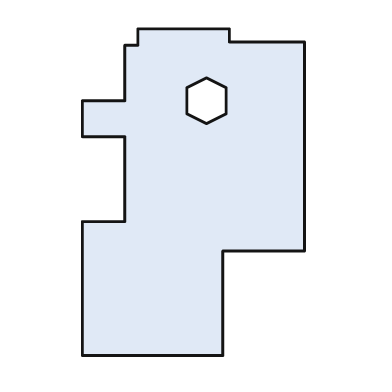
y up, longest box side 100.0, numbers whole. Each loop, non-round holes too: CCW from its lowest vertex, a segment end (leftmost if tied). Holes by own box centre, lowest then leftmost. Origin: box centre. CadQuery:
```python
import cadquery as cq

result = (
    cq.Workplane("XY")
    .moveTo(-34.0, -50.0)
    .lineTo(9.0, -50.0)
    .lineTo(9.0, -18.0)
    .lineTo(34.0, -18.0)
    .lineTo(34.0, 46.0)
    .lineTo(11.0, 46.0)
    .lineTo(11.0, 50.0)
    .lineTo(-17.0, 50.0)
    .lineTo(-17.0, 45.0)
    .lineTo(-21.0, 45.0)
    .lineTo(-21.0, 28.0)
    .lineTo(-34.0, 28.0)
    .lineTo(-34.0, 17.0)
    .lineTo(-21.0, 17.0)
    .lineTo(-21.0, -9.0)
    .lineTo(-34.0, -9.0)
    .close()
    .moveTo(4.0, 21.0)
    .lineTo(10.0, 24.0)
    .lineTo(10.0, 32.0)
    .lineTo(4.0, 35.0)
    .lineTo(-2.0, 32.0)
    .lineTo(-2.0, 24.0)
    .close()
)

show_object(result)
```